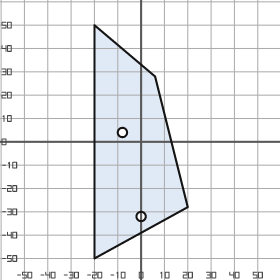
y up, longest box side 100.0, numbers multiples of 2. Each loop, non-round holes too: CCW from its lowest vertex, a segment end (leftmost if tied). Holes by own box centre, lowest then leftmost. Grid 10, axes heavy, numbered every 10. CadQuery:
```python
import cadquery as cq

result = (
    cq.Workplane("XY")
    .moveTo(-20.0, -50.0)
    .lineTo(20.0, -28.0)
    .lineTo(6.0, 28.0)
    .lineTo(-20.0, 50.0)
    .close()
    .moveTo(0.0, -32.0)
    .circle(2.0)
    .moveTo(-8.0, 4.0)
    .circle(2.0)
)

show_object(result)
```